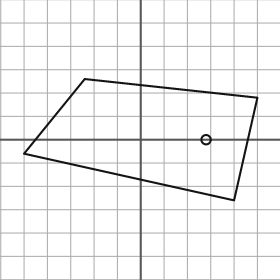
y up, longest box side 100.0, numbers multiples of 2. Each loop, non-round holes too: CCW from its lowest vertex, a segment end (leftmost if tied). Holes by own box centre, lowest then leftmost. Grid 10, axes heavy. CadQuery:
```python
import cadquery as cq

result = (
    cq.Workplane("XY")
    .moveTo(40.0, -26.0)
    .lineTo(50.0, 18.0)
    .lineTo(-24.0, 26.0)
    .lineTo(-50.0, -6.0)
    .close()
    .moveTo(28.0, 0.0)
    .circle(2.0)
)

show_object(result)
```